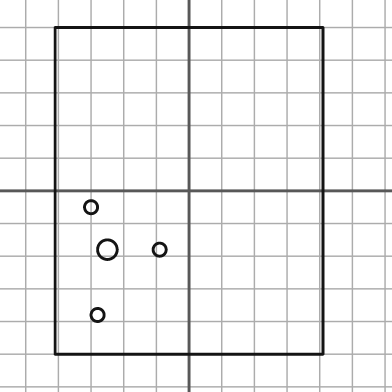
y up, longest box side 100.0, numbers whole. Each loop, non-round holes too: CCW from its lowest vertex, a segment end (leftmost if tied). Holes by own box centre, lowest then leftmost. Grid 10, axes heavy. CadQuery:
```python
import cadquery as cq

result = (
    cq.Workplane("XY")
    .moveTo(-41.0, -50.0)
    .lineTo(41.0, -50.0)
    .lineTo(41.0, 50.0)
    .lineTo(-41.0, 50.0)
    .close()
    .moveTo(-28.0, -38.0)
    .circle(2.0)
    .moveTo(-25.0, -18.0)
    .circle(3.0)
    .moveTo(-9.0, -18.0)
    .circle(2.0)
    .moveTo(-30.0, -5.0)
    .circle(2.0)
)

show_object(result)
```